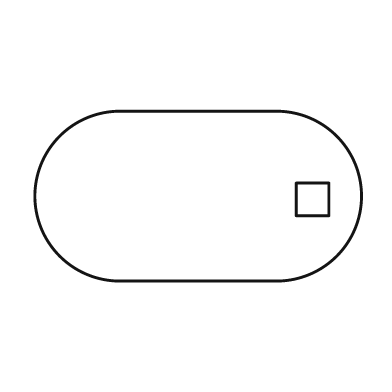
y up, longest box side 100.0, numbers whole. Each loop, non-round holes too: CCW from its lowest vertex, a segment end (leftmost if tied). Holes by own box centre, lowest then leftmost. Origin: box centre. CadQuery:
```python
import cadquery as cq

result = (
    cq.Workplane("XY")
    .moveTo(-24.0, -26.0)
    .lineTo(24.0, -26.0)
    .threePointArc((50.0, 0.0), (24.0, 26.0))
    .lineTo(-24.0, 26.0)
    .threePointArc((-50.0, 0.0), (-24.0, -26.0))
    .close()
    .moveTo(30.0, -6.0)
    .lineTo(40.0, -6.0)
    .lineTo(40.0, 4.0)
    .lineTo(30.0, 4.0)
    .close()
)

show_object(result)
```